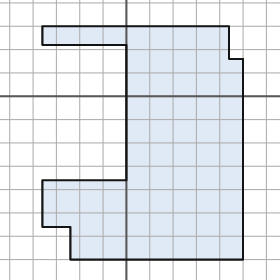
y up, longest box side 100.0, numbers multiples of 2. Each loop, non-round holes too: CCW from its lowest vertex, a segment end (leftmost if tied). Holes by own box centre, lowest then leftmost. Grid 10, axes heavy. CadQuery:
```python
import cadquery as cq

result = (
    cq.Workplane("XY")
    .moveTo(-24.0, -70.0)
    .lineTo(50.0, -70.0)
    .lineTo(50.0, 16.0)
    .lineTo(44.0, 16.0)
    .lineTo(44.0, 30.0)
    .lineTo(-36.0, 30.0)
    .lineTo(-36.0, 22.0)
    .lineTo(0.0, 22.0)
    .lineTo(0.0, -36.0)
    .lineTo(-36.0, -36.0)
    .lineTo(-36.0, -56.0)
    .lineTo(-24.0, -56.0)
    .close()
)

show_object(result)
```